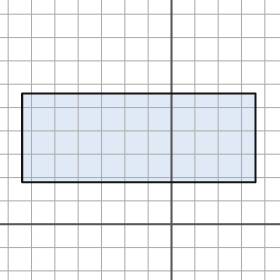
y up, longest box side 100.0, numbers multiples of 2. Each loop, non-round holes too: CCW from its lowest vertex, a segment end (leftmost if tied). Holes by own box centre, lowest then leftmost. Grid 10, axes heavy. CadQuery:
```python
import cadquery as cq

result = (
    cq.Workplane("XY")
    .moveTo(-64.0, 18.0)
    .lineTo(36.0, 18.0)
    .lineTo(36.0, 56.0)
    .lineTo(-64.0, 56.0)
    .close()
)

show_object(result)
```